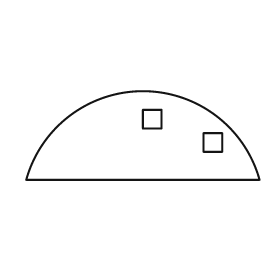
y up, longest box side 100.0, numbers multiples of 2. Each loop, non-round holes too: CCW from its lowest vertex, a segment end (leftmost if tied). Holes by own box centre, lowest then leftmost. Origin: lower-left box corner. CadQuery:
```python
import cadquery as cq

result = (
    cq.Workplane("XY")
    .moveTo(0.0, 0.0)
    .lineTo(100.0, 0.0)
    .threePointArc((50.0, 38.0), (0.0, 0.0))
    .close()
    .moveTo(76.0, 12.0)
    .lineTo(84.0, 12.0)
    .lineTo(84.0, 20.0)
    .lineTo(76.0, 20.0)
    .close()
    .moveTo(50.0, 22.0)
    .lineTo(58.0, 22.0)
    .lineTo(58.0, 30.0)
    .lineTo(50.0, 30.0)
    .close()
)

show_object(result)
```